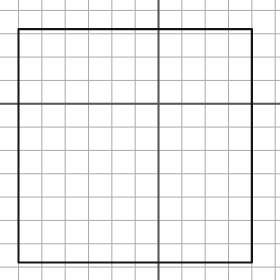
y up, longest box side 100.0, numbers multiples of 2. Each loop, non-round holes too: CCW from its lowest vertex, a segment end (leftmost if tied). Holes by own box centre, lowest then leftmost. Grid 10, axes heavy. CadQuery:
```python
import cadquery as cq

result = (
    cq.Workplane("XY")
    .moveTo(-60.0, -68.0)
    .lineTo(40.0, -68.0)
    .lineTo(40.0, 32.0)
    .lineTo(-60.0, 32.0)
    .close()
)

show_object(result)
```